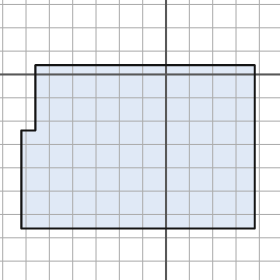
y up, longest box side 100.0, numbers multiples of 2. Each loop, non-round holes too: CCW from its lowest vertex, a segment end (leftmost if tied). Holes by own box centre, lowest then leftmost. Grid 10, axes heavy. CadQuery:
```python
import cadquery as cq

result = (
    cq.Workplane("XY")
    .moveTo(-62.0, -66.0)
    .lineTo(38.0, -66.0)
    .lineTo(38.0, 4.0)
    .lineTo(-56.0, 4.0)
    .lineTo(-56.0, -24.0)
    .lineTo(-62.0, -24.0)
    .close()
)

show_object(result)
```